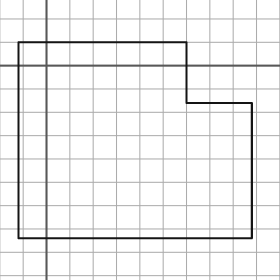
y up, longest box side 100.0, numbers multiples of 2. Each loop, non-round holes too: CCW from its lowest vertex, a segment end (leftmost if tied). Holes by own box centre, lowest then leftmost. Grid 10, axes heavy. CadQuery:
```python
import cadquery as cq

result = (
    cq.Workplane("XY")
    .moveTo(-12.0, -74.0)
    .lineTo(88.0, -74.0)
    .lineTo(88.0, -16.0)
    .lineTo(60.0, -16.0)
    .lineTo(60.0, 10.0)
    .lineTo(-12.0, 10.0)
    .close()
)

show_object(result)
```